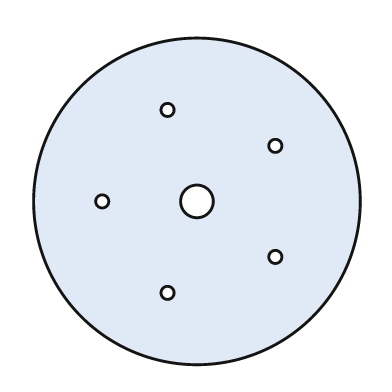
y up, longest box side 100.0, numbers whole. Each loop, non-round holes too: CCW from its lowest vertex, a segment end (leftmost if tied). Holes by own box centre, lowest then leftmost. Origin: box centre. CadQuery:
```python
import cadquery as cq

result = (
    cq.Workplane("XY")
    .moveTo(0.0, 0.0)
    .circle(50.0)
    .moveTo(-9.0, -28.0)
    .circle(2.0)
    .moveTo(24.0, -17.0)
    .circle(2.0)
    .moveTo(-29.0, 0.0)
    .circle(2.0)
    .moveTo(0.0, 0.0)
    .circle(5.0)
    .moveTo(24.0, 17.0)
    .circle(2.0)
    .moveTo(-9.0, 28.0)
    .circle(2.0)
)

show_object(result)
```